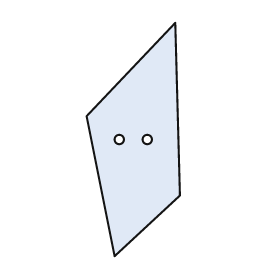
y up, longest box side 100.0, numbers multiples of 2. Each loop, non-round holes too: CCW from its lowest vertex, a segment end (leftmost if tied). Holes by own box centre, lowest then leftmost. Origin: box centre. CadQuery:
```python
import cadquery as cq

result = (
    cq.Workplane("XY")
    .moveTo(-8.0, -50.0)
    .lineTo(20.0, -24.0)
    .lineTo(18.0, 50.0)
    .lineTo(-20.0, 10.0)
    .close()
    .moveTo(-6.0, 0.0)
    .circle(2.0)
    .moveTo(6.0, 0.0)
    .circle(2.0)
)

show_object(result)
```